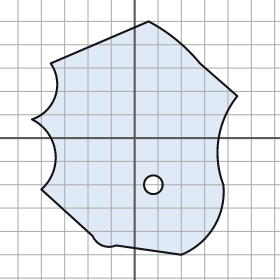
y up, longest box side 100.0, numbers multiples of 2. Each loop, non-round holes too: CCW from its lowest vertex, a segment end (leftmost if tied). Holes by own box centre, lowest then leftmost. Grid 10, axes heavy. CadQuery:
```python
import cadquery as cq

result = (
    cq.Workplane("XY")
    .moveTo(20.0, -50.0)
    .threePointArc((34.0, -38.0), (38.0, -20.0))
    .threePointArc((36.0, 0.0), (44.0, 18.0))
    .lineTo(28.0, 32.0)
    .threePointArc((18.0, 42.0), (6.0, 50.0))
    .lineTo(-36.0, 32.0)
    .threePointArc((-34.0, 18.0), (-44.0, 8.0))
    .threePointArc((-34.0, -6.0), (-40.0, -22.0))
    .lineTo(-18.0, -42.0)
    .threePointArc((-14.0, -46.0), (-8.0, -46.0))
    .close()
    .moveTo(8.0, -20.0)
    .circle(4.0)
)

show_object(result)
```